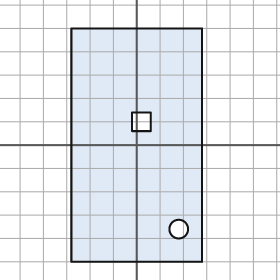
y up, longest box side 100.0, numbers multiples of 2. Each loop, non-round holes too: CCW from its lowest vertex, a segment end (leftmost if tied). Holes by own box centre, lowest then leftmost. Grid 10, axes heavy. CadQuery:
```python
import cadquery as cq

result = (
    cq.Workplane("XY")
    .moveTo(-28.0, -50.0)
    .lineTo(28.0, -50.0)
    .lineTo(28.0, 50.0)
    .lineTo(-28.0, 50.0)
    .close()
    .moveTo(18.0, -36.0)
    .circle(4.0)
    .moveTo(-2.0, 6.0)
    .lineTo(6.0, 6.0)
    .lineTo(6.0, 14.0)
    .lineTo(-2.0, 14.0)
    .close()
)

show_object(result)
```